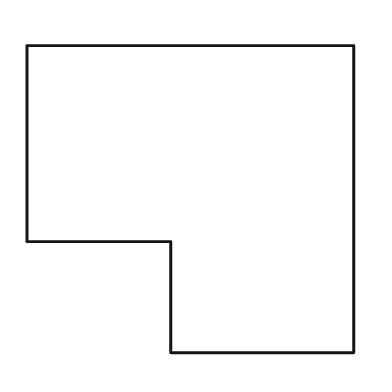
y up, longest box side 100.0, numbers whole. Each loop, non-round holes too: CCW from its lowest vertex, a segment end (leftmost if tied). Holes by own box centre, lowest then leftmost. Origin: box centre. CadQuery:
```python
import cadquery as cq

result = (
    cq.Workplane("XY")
    .moveTo(-6.0, -47.0)
    .lineTo(50.0, -47.0)
    .lineTo(50.0, 47.0)
    .lineTo(-50.0, 47.0)
    .lineTo(-50.0, -13.0)
    .lineTo(-6.0, -13.0)
    .close()
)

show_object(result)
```